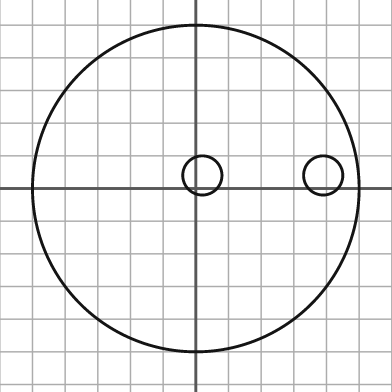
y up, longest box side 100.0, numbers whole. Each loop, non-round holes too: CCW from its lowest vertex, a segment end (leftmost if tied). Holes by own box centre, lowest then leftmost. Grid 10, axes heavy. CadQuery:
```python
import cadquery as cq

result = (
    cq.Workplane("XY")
    .moveTo(0.0, 0.0)
    .circle(50.0)
    .moveTo(2.0, 4.0)
    .circle(6.0)
    .moveTo(39.0, 4.0)
    .circle(6.0)
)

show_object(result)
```